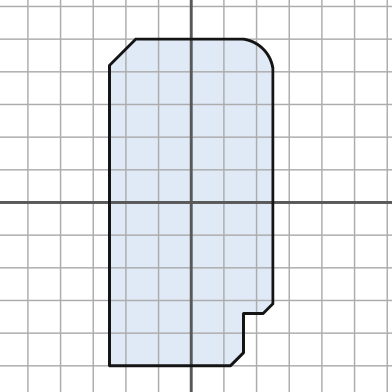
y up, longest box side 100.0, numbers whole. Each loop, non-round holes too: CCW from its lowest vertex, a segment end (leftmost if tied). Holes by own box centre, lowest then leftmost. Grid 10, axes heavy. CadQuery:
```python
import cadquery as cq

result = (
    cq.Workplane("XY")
    .moveTo(-25.0, -50.0)
    .lineTo(12.0, -50.0)
    .lineTo(16.0, -46.0)
    .lineTo(16.0, -34.0)
    .lineTo(22.0, -34.0)
    .lineTo(25.0, -31.0)
    .lineTo(25.0, 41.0)
    .threePointArc((22.0, 47.0), (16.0, 50.0))
    .lineTo(-17.0, 50.0)
    .lineTo(-25.0, 42.0)
    .close()
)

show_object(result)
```